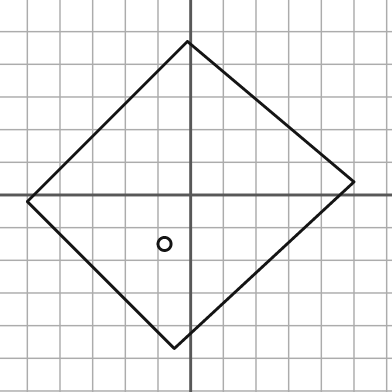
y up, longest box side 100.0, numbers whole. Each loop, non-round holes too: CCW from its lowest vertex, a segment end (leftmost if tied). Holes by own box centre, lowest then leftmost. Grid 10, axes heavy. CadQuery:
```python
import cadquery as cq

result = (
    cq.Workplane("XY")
    .moveTo(-5.0, -47.0)
    .lineTo(50.0, 4.0)
    .lineTo(-1.0, 47.0)
    .lineTo(-50.0, -2.0)
    .close()
    .moveTo(-8.0, -15.0)
    .circle(2.0)
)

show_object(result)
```